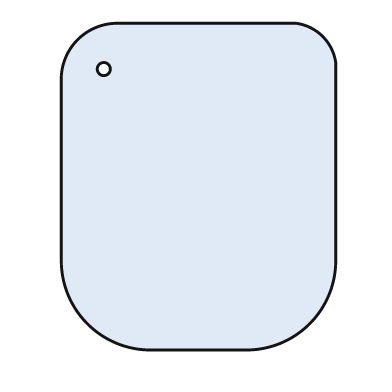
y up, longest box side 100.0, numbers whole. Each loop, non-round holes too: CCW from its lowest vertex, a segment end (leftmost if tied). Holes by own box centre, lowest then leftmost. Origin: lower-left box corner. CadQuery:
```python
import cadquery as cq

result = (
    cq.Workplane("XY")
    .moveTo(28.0, 0.0)
    .lineTo(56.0, 0.0)
    .threePointArc((76.0, 8.0), (84.0, 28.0))
    .lineTo(84.0, 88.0)
    .threePointArc((80.0, 96.0), (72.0, 100.0))
    .lineTo(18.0, 100.0)
    .threePointArc((5.0, 95.0), (0.0, 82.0))
    .lineTo(0.0, 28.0)
    .threePointArc((8.0, 8.0), (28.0, 0.0))
    .close()
    .moveTo(13.0, 86.0)
    .circle(2.0)
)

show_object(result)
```